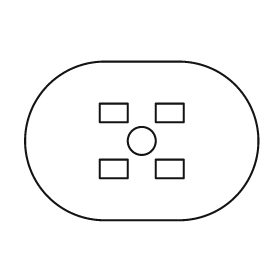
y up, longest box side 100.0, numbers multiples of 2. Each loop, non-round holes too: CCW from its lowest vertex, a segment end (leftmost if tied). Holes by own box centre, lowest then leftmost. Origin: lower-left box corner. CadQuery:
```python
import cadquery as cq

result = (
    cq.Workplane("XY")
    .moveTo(34.0, 0.0)
    .lineTo(66.0, 0.0)
    .threePointArc((100.0, 34.0), (66.0, 68.0))
    .lineTo(34.0, 68.0)
    .threePointArc((0.0, 34.0), (34.0, 0.0))
    .close()
    .moveTo(32.0, 18.0)
    .lineTo(44.0, 18.0)
    .lineTo(44.0, 26.0)
    .lineTo(32.0, 26.0)
    .close()
    .moveTo(56.0, 18.0)
    .lineTo(68.0, 18.0)
    .lineTo(68.0, 26.0)
    .lineTo(56.0, 26.0)
    .close()
    .moveTo(50.0, 34.0)
    .circle(6.0)
    .moveTo(32.0, 42.0)
    .lineTo(44.0, 42.0)
    .lineTo(44.0, 50.0)
    .lineTo(32.0, 50.0)
    .close()
    .moveTo(56.0, 42.0)
    .lineTo(68.0, 42.0)
    .lineTo(68.0, 50.0)
    .lineTo(56.0, 50.0)
    .close()
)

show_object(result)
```